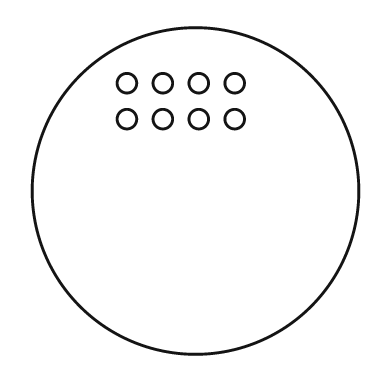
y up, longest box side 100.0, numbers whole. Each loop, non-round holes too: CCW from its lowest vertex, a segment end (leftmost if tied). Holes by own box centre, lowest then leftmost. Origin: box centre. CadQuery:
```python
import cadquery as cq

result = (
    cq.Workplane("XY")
    .moveTo(0.0, 0.0)
    .circle(50.0)
    .moveTo(-21.0, 22.0)
    .circle(3.0)
    .moveTo(-10.0, 22.0)
    .circle(3.0)
    .moveTo(1.0, 22.0)
    .circle(3.0)
    .moveTo(12.0, 22.0)
    .circle(3.0)
    .moveTo(-21.0, 33.0)
    .circle(3.0)
    .moveTo(-10.0, 33.0)
    .circle(3.0)
    .moveTo(1.0, 33.0)
    .circle(3.0)
    .moveTo(12.0, 33.0)
    .circle(3.0)
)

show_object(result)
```